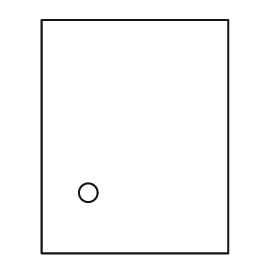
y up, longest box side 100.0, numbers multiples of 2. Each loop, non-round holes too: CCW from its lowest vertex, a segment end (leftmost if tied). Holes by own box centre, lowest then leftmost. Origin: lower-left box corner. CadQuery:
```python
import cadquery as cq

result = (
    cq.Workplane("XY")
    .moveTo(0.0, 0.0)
    .lineTo(80.0, 0.0)
    .lineTo(80.0, 100.0)
    .lineTo(0.0, 100.0)
    .close()
    .moveTo(20.0, 26.0)
    .circle(4.0)
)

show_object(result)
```